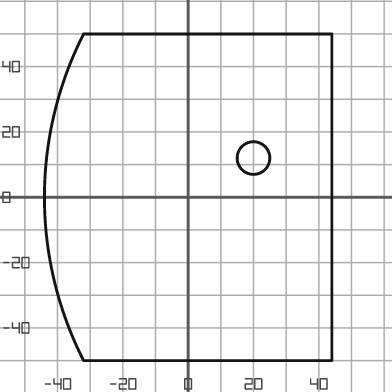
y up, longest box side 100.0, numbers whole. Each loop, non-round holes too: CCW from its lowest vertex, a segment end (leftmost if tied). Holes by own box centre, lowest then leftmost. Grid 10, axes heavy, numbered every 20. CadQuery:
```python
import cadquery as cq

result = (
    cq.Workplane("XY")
    .moveTo(-32.0, -50.0)
    .lineTo(44.0, -50.0)
    .lineTo(44.0, 50.0)
    .lineTo(-32.0, 50.0)
    .threePointArc((-44.0, 0.0), (-32.0, -50.0))
    .close()
    .moveTo(20.0, 12.0)
    .circle(5.0)
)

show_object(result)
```